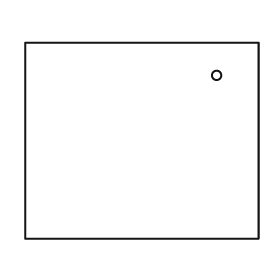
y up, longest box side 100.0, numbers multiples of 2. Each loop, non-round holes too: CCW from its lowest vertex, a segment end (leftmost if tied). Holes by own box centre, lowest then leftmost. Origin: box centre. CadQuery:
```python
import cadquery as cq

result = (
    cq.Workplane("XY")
    .moveTo(-50.0, -42.0)
    .lineTo(50.0, -42.0)
    .lineTo(50.0, 42.0)
    .lineTo(-50.0, 42.0)
    .close()
    .moveTo(32.0, 28.0)
    .circle(2.0)
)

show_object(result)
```